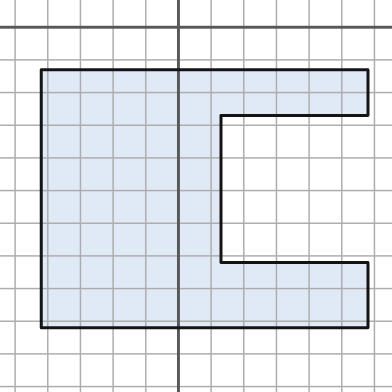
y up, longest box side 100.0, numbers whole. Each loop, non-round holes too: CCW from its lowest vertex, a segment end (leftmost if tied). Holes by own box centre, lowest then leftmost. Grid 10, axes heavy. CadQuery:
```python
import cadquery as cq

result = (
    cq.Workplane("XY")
    .moveTo(-42.0, -92.0)
    .lineTo(58.0, -92.0)
    .lineTo(58.0, -72.0)
    .lineTo(13.0, -72.0)
    .lineTo(13.0, -27.0)
    .lineTo(58.0, -27.0)
    .lineTo(58.0, -13.0)
    .lineTo(-42.0, -13.0)
    .close()
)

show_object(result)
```